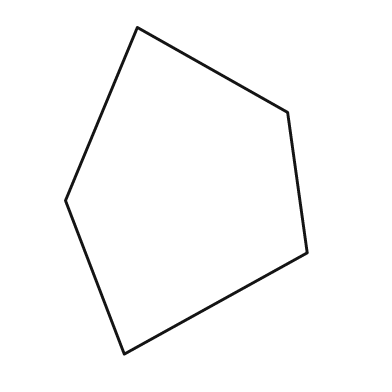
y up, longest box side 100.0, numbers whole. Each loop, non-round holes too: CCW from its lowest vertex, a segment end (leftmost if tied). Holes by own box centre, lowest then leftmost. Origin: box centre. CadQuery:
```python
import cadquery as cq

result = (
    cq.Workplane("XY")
    .moveTo(-19.0, -50.0)
    .lineTo(37.0, -19.0)
    .lineTo(31.0, 24.0)
    .lineTo(-15.0, 50.0)
    .lineTo(-37.0, -3.0)
    .close()
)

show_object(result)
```